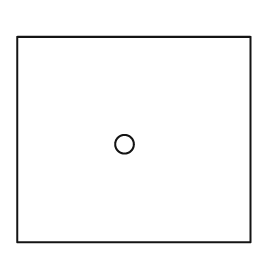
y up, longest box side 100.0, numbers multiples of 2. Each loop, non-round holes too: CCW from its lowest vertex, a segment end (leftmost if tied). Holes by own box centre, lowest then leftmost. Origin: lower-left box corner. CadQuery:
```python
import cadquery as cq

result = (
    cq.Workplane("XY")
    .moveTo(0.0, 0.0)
    .lineTo(100.0, 0.0)
    .lineTo(100.0, 88.0)
    .lineTo(0.0, 88.0)
    .close()
    .moveTo(46.0, 42.0)
    .circle(4.0)
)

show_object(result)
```